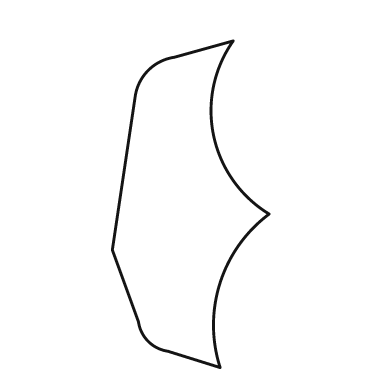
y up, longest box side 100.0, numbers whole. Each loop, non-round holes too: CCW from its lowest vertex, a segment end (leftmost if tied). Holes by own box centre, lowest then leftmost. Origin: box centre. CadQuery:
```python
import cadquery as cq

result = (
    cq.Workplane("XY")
    .moveTo(9.0, -50.0)
    .threePointArc((9.0, -24.0), (24.0, -3.0))
    .threePointArc((7.0, 21.0), (13.0, 50.0))
    .lineTo(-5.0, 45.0)
    .threePointArc((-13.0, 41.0), (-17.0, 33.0))
    .lineTo(-24.0, -14.0)
    .lineTo(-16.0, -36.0)
    .threePointArc((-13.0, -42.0), (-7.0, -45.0))
    .close()
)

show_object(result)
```